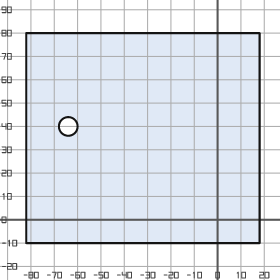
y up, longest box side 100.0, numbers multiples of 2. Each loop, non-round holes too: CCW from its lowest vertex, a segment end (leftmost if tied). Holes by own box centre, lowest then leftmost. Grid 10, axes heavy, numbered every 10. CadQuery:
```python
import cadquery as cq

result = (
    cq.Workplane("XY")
    .moveTo(-82.0, -10.0)
    .lineTo(18.0, -10.0)
    .lineTo(18.0, 80.0)
    .lineTo(-82.0, 80.0)
    .close()
    .moveTo(-64.0, 40.0)
    .circle(4.0)
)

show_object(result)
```